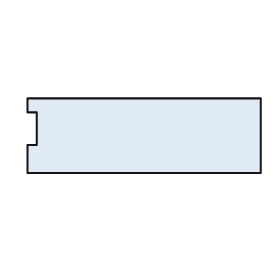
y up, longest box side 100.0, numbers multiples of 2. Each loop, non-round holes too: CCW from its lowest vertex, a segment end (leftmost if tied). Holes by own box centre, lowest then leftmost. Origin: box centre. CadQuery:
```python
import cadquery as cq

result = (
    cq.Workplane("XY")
    .moveTo(-50.0, -16.0)
    .lineTo(50.0, -16.0)
    .lineTo(50.0, 16.0)
    .lineTo(-50.0, 16.0)
    .lineTo(-50.0, 10.0)
    .lineTo(-46.0, 10.0)
    .lineTo(-46.0, -4.0)
    .lineTo(-50.0, -4.0)
    .close()
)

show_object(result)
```